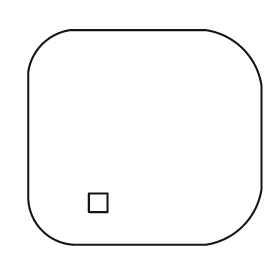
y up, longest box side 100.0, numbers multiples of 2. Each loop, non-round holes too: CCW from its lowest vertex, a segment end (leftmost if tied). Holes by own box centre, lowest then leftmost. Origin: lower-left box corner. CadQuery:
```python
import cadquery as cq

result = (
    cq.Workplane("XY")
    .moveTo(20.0, 0.0)
    .lineTo(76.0, 0.0)
    .threePointArc((92.0, 8.0), (100.0, 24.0))
    .lineTo(100.0, 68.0)
    .threePointArc((92.0, 84.0), (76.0, 92.0))
    .lineTo(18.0, 92.0)
    .threePointArc((6.0, 86.0), (0.0, 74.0))
    .lineTo(0.0, 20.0)
    .threePointArc((6.0, 6.0), (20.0, 0.0))
    .close()
    .moveTo(26.0, 14.0)
    .lineTo(34.0, 14.0)
    .lineTo(34.0, 22.0)
    .lineTo(26.0, 22.0)
    .close()
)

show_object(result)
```